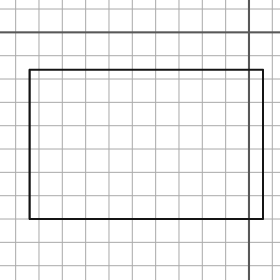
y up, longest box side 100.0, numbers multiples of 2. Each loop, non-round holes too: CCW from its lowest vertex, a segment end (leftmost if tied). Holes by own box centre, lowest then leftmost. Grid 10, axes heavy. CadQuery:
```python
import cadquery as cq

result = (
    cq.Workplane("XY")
    .moveTo(-94.0, -80.0)
    .lineTo(6.0, -80.0)
    .lineTo(6.0, -16.0)
    .lineTo(-94.0, -16.0)
    .close()
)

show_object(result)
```